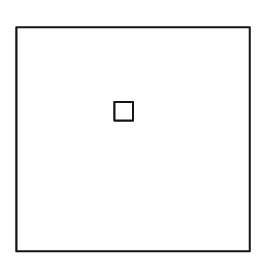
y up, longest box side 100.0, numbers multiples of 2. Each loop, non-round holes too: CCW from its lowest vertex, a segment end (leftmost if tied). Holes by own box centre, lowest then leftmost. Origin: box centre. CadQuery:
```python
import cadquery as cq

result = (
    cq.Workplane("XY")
    .moveTo(-50.0, -48.0)
    .lineTo(50.0, -48.0)
    .lineTo(50.0, 48.0)
    .lineTo(-50.0, 48.0)
    .close()
    .moveTo(-8.0, 8.0)
    .lineTo(0.0, 8.0)
    .lineTo(0.0, 16.0)
    .lineTo(-8.0, 16.0)
    .close()
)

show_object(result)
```